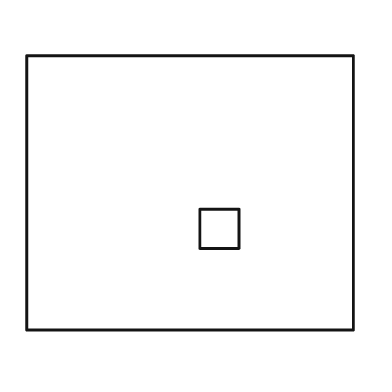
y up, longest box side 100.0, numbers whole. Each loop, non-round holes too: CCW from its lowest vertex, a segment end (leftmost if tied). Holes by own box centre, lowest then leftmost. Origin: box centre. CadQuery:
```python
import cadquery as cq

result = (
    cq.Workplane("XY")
    .moveTo(-50.0, -42.0)
    .lineTo(50.0, -42.0)
    .lineTo(50.0, 42.0)
    .lineTo(-50.0, 42.0)
    .close()
    .moveTo(3.0, -17.0)
    .lineTo(15.0, -17.0)
    .lineTo(15.0, -5.0)
    .lineTo(3.0, -5.0)
    .close()
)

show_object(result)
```